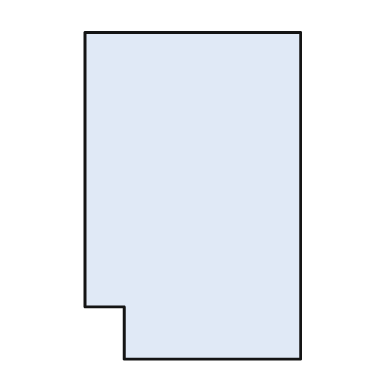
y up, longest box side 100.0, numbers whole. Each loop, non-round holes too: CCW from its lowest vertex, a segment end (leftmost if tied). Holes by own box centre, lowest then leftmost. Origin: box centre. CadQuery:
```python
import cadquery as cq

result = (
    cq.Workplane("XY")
    .moveTo(-21.0, -50.0)
    .lineTo(33.0, -50.0)
    .lineTo(33.0, 50.0)
    .lineTo(-33.0, 50.0)
    .lineTo(-33.0, -34.0)
    .lineTo(-21.0, -34.0)
    .close()
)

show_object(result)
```